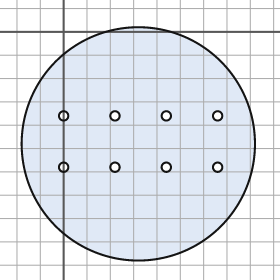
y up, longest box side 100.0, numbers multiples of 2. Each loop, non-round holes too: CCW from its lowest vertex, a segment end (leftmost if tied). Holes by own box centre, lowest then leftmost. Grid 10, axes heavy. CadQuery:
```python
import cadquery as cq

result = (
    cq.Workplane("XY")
    .moveTo(32.0, -48.0)
    .circle(50.0)
    .moveTo(0.0, -58.0)
    .circle(2.0)
    .moveTo(22.0, -58.0)
    .circle(2.0)
    .moveTo(44.0, -58.0)
    .circle(2.0)
    .moveTo(66.0, -58.0)
    .circle(2.0)
    .moveTo(0.0, -36.0)
    .circle(2.0)
    .moveTo(22.0, -36.0)
    .circle(2.0)
    .moveTo(44.0, -36.0)
    .circle(2.0)
    .moveTo(66.0, -36.0)
    .circle(2.0)
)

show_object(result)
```